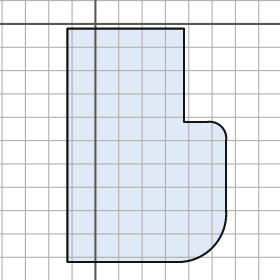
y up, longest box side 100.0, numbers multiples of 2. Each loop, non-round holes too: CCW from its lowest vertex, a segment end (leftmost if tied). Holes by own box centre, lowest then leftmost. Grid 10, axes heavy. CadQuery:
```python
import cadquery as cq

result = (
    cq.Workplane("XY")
    .moveTo(-12.0, -102.0)
    .lineTo(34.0, -102.0)
    .threePointArc((50.0, -96.0), (56.0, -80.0))
    .lineTo(56.0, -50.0)
    .threePointArc((54.0, -44.0), (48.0, -42.0))
    .lineTo(38.0, -42.0)
    .lineTo(38.0, -2.0)
    .lineTo(-12.0, -2.0)
    .close()
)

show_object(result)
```